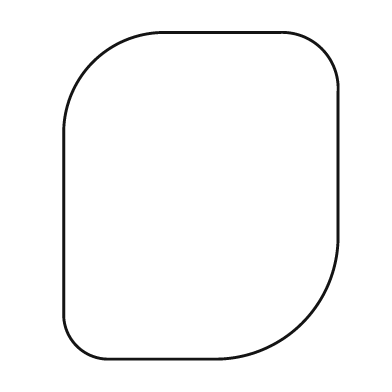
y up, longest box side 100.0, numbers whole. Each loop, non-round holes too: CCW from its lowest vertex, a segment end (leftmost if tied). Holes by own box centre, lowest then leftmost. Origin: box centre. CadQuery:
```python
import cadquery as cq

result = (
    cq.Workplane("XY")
    .moveTo(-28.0, -50.0)
    .lineTo(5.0, -50.0)
    .threePointArc((31.0, -39.0), (42.0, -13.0))
    .lineTo(42.0, 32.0)
    .threePointArc((37.0, 45.0), (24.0, 50.0))
    .lineTo(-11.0, 50.0)
    .threePointArc((-33.0, 41.0), (-42.0, 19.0))
    .lineTo(-42.0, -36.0)
    .threePointArc((-38.0, -46.0), (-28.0, -50.0))
    .close()
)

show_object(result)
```